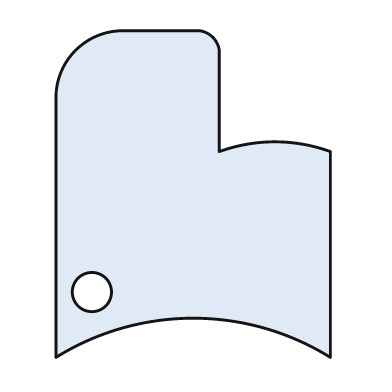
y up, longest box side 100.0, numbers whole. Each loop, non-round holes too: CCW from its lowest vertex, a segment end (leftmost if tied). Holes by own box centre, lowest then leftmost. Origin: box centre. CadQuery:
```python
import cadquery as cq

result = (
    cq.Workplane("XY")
    .moveTo(-42.0, -50.0)
    .threePointArc((0.0, -38.0), (42.0, -50.0))
    .lineTo(42.0, 13.0)
    .threePointArc((25.0, 16.0), (8.0, 13.0))
    .lineTo(8.0, 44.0)
    .threePointArc((6.0, 48.0), (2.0, 50.0))
    .lineTo(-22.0, 50.0)
    .threePointArc((-36.0, 44.0), (-42.0, 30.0))
    .close()
    .moveTo(-31.0, -30.0)
    .circle(6.0)
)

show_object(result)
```